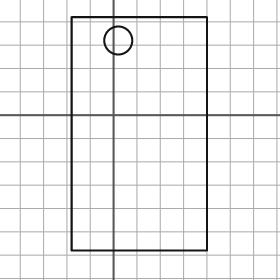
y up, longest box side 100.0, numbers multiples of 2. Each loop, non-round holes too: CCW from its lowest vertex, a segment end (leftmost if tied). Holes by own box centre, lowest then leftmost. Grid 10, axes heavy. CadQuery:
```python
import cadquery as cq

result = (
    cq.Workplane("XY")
    .moveTo(-18.0, -58.0)
    .lineTo(40.0, -58.0)
    .lineTo(40.0, 42.0)
    .lineTo(-18.0, 42.0)
    .close()
    .moveTo(2.0, 32.0)
    .circle(6.0)
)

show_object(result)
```